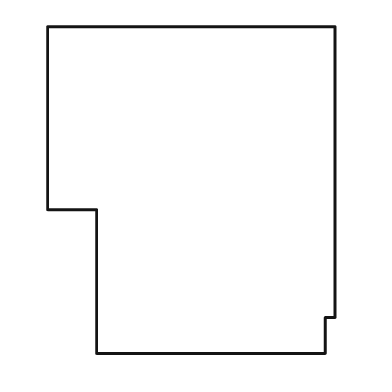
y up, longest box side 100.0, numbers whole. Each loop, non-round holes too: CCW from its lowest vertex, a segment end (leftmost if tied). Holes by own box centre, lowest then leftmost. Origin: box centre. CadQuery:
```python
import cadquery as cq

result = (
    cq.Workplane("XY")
    .moveTo(-29.0, -50.0)
    .lineTo(41.0, -50.0)
    .lineTo(41.0, -39.0)
    .lineTo(44.0, -39.0)
    .lineTo(44.0, 50.0)
    .lineTo(-44.0, 50.0)
    .lineTo(-44.0, -6.0)
    .lineTo(-29.0, -6.0)
    .close()
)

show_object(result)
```